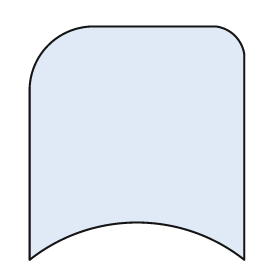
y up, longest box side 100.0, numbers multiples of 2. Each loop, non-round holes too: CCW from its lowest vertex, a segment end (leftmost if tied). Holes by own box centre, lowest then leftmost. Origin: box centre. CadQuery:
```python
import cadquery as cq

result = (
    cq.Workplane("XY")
    .moveTo(-46.0, -50.0)
    .threePointArc((0.0, -34.0), (46.0, -50.0))
    .lineTo(46.0, 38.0)
    .threePointArc((42.0, 46.0), (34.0, 50.0))
    .lineTo(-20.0, 50.0)
    .threePointArc((-38.0, 42.0), (-46.0, 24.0))
    .close()
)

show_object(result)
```